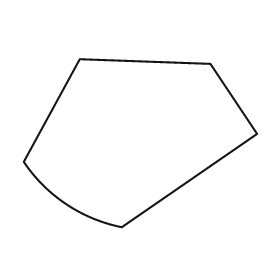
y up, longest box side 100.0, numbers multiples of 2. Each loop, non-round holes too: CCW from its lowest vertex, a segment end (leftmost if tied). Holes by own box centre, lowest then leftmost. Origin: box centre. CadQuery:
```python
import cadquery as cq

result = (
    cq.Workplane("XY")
    .moveTo(-8.0, -36.0)
    .lineTo(50.0, 4.0)
    .lineTo(30.0, 34.0)
    .lineTo(-26.0, 36.0)
    .lineTo(-50.0, -8.0)
    .threePointArc((-32.0, -26.0), (-8.0, -36.0))
    .close()
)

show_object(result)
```